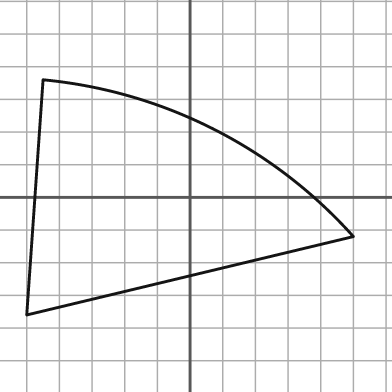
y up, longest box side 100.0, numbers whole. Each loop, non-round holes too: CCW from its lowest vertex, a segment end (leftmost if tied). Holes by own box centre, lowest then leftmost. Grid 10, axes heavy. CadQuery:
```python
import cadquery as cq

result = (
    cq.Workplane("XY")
    .moveTo(-50.0, -36.0)
    .lineTo(50.0, -12.0)
    .threePointArc((7.0, 21.0), (-45.0, 36.0))
    .close()
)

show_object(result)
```